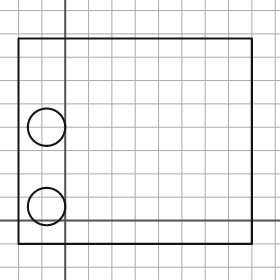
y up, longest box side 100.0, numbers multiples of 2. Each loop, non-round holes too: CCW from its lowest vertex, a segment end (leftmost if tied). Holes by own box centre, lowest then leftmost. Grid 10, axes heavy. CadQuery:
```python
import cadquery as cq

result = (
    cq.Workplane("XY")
    .moveTo(-20.0, -10.0)
    .lineTo(80.0, -10.0)
    .lineTo(80.0, 78.0)
    .lineTo(-20.0, 78.0)
    .close()
    .moveTo(-8.0, 6.0)
    .circle(8.0)
    .moveTo(-8.0, 40.0)
    .circle(8.0)
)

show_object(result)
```